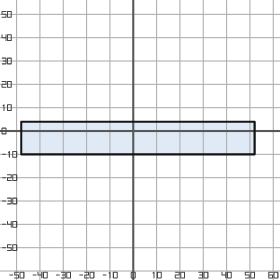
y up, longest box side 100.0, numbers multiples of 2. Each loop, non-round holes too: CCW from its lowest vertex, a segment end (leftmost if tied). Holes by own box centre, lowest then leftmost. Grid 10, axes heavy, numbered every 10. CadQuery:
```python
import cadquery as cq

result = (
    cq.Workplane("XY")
    .moveTo(-48.0, -10.0)
    .lineTo(52.0, -10.0)
    .lineTo(52.0, 4.0)
    .lineTo(-48.0, 4.0)
    .close()
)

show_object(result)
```